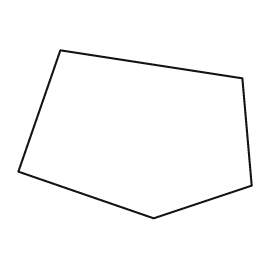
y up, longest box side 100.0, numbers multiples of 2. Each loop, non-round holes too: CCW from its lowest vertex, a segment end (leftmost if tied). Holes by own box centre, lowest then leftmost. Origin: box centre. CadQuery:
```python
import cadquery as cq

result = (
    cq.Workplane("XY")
    .moveTo(8.0, -36.0)
    .lineTo(50.0, -22.0)
    .lineTo(46.0, 24.0)
    .lineTo(-32.0, 36.0)
    .lineTo(-50.0, -16.0)
    .close()
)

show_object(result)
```